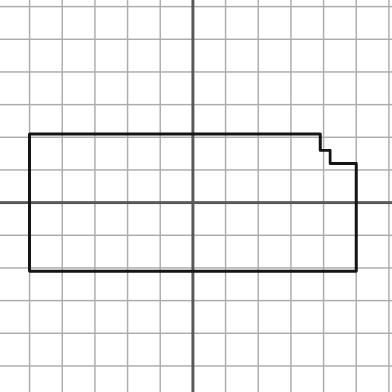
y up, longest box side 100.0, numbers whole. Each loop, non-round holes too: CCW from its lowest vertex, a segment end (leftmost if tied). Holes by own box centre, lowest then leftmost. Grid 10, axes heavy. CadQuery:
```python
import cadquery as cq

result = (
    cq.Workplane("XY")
    .moveTo(-50.0, -21.0)
    .lineTo(50.0, -21.0)
    .lineTo(50.0, 12.0)
    .lineTo(42.0, 12.0)
    .lineTo(42.0, 16.0)
    .lineTo(39.0, 16.0)
    .lineTo(39.0, 21.0)
    .lineTo(-50.0, 21.0)
    .close()
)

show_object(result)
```